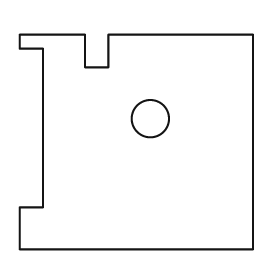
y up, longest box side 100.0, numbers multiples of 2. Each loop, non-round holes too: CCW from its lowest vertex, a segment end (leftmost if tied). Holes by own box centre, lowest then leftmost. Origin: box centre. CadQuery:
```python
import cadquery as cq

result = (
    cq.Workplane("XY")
    .moveTo(-50.0, -46.0)
    .lineTo(50.0, -46.0)
    .lineTo(50.0, 46.0)
    .lineTo(-12.0, 46.0)
    .lineTo(-12.0, 32.0)
    .lineTo(-22.0, 32.0)
    .lineTo(-22.0, 46.0)
    .lineTo(-50.0, 46.0)
    .lineTo(-50.0, 40.0)
    .lineTo(-40.0, 40.0)
    .lineTo(-40.0, -28.0)
    .lineTo(-50.0, -28.0)
    .close()
    .moveTo(6.0, 10.0)
    .circle(8.0)
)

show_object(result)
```